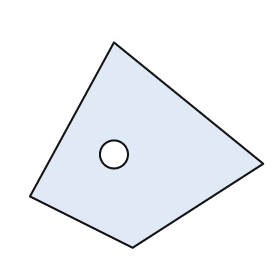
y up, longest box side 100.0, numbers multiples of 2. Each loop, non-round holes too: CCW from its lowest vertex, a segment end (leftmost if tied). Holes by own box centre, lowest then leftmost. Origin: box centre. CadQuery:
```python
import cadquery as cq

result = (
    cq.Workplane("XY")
    .moveTo(-6.0, -44.0)
    .lineTo(50.0, -8.0)
    .lineTo(-14.0, 44.0)
    .lineTo(-50.0, -22.0)
    .close()
    .moveTo(-14.0, -4.0)
    .circle(6.0)
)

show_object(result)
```